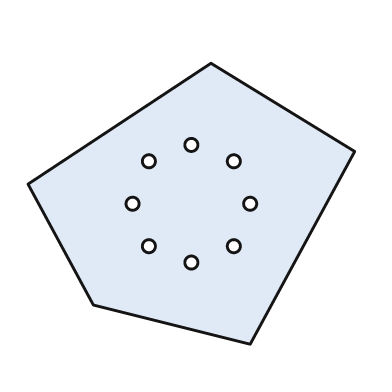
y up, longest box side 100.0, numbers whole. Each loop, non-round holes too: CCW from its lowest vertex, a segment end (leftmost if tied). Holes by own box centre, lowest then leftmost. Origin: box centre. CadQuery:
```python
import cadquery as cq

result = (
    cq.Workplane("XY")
    .moveTo(18.0, -43.0)
    .lineTo(50.0, 16.0)
    .lineTo(6.0, 43.0)
    .lineTo(-50.0, 6.0)
    .lineTo(-30.0, -31.0)
    .close()
    .moveTo(0.0, -18.0)
    .circle(2.0)
    .moveTo(-13.0, -13.0)
    .circle(2.0)
    .moveTo(13.0, -13.0)
    .circle(2.0)
    .moveTo(-18.0, 0.0)
    .circle(2.0)
    .moveTo(18.0, 0.0)
    .circle(2.0)
    .moveTo(-13.0, 13.0)
    .circle(2.0)
    .moveTo(13.0, 13.0)
    .circle(2.0)
    .moveTo(0.0, 18.0)
    .circle(2.0)
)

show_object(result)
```